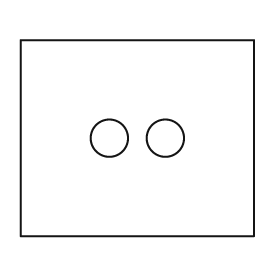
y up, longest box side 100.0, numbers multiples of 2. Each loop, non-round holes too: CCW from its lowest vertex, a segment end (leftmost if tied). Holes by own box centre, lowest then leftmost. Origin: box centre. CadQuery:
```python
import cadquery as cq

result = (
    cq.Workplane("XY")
    .moveTo(-50.0, -42.0)
    .lineTo(50.0, -42.0)
    .lineTo(50.0, 42.0)
    .lineTo(-50.0, 42.0)
    .close()
    .moveTo(-12.0, 0.0)
    .circle(8.0)
    .moveTo(12.0, 0.0)
    .circle(8.0)
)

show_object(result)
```